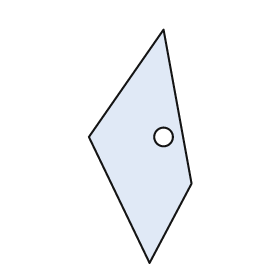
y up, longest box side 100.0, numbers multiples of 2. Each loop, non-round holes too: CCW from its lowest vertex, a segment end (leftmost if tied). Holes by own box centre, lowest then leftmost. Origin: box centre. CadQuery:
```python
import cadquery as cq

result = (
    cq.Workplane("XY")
    .moveTo(4.0, -50.0)
    .lineTo(22.0, -16.0)
    .lineTo(10.0, 50.0)
    .lineTo(-22.0, 4.0)
    .close()
    .moveTo(10.0, 4.0)
    .circle(4.0)
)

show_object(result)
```